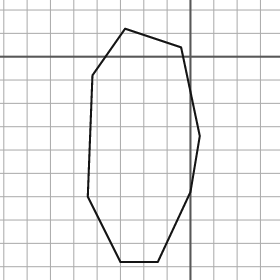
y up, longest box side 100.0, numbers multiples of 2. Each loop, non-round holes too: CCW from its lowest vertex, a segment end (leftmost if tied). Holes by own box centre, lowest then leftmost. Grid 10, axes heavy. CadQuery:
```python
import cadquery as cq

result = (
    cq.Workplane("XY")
    .moveTo(-30.0, -88.0)
    .lineTo(-14.0, -88.0)
    .lineTo(0.0, -58.0)
    .lineTo(4.0, -34.0)
    .lineTo(-4.0, 4.0)
    .lineTo(-28.0, 12.0)
    .lineTo(-42.0, -8.0)
    .lineTo(-44.0, -60.0)
    .close()
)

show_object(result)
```